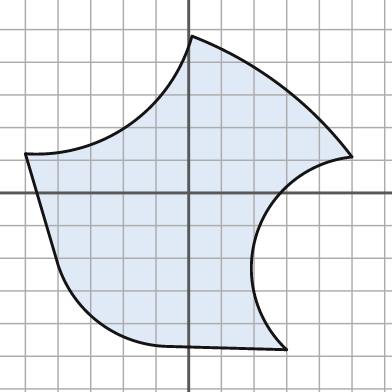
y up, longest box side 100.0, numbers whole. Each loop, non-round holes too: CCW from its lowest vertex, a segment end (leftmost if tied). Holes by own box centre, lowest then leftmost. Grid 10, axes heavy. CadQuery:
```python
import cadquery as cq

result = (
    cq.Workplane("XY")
    .moveTo(30.0, -48.0)
    .threePointArc((21.0, -12.0), (50.0, 11.0))
    .threePointArc((28.0, 33.0), (1.0, 48.0))
    .threePointArc((-18.0, 21.0), (-50.0, 12.0))
    .lineTo(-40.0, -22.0)
    .threePointArc((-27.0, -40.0), (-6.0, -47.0))
    .close()
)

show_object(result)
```